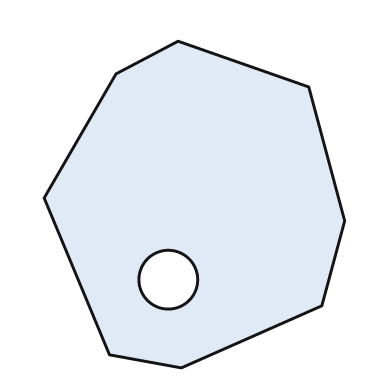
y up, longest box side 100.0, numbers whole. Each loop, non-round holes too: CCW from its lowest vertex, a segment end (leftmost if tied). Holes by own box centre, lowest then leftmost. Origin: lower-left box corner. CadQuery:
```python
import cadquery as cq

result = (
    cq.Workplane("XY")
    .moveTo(42.0, 0.0)
    .lineTo(85.0, 19.0)
    .lineTo(92.0, 45.0)
    .lineTo(81.0, 86.0)
    .lineTo(41.0, 100.0)
    .lineTo(22.0, 90.0)
    .lineTo(0.0, 52.0)
    .lineTo(20.0, 4.0)
    .close()
    .moveTo(38.0, 27.0)
    .circle(9.0)
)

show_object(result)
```